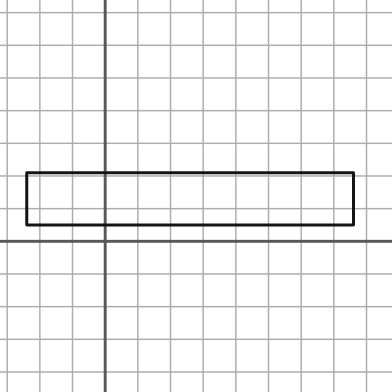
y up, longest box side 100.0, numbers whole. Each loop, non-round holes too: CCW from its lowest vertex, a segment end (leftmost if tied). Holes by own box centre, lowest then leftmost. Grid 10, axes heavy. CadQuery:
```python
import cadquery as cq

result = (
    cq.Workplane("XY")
    .moveTo(-24.0, 5.0)
    .lineTo(76.0, 5.0)
    .lineTo(76.0, 21.0)
    .lineTo(-24.0, 21.0)
    .close()
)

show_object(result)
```